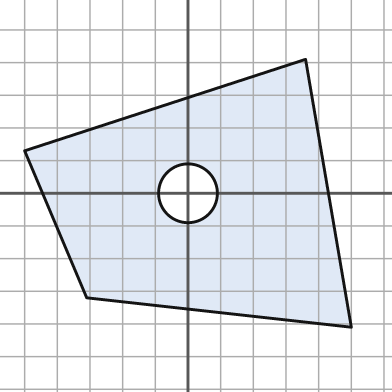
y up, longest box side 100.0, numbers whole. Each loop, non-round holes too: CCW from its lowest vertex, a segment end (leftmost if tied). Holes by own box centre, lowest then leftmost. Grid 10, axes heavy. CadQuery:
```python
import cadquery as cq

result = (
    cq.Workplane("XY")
    .moveTo(50.0, -41.0)
    .lineTo(36.0, 41.0)
    .lineTo(-50.0, 13.0)
    .lineTo(-31.0, -32.0)
    .close()
    .moveTo(0.0, 0.0)
    .circle(9.0)
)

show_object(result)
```